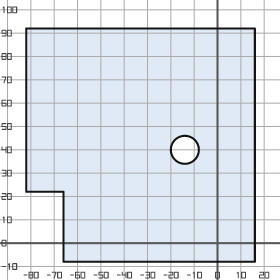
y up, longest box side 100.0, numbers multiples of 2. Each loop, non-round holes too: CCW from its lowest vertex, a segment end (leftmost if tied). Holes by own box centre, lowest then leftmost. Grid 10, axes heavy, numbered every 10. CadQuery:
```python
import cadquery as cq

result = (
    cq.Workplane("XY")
    .moveTo(-66.0, -8.0)
    .lineTo(16.0, -8.0)
    .lineTo(16.0, 92.0)
    .lineTo(-82.0, 92.0)
    .lineTo(-82.0, 22.0)
    .lineTo(-66.0, 22.0)
    .close()
    .moveTo(-14.0, 40.0)
    .circle(6.0)
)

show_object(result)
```